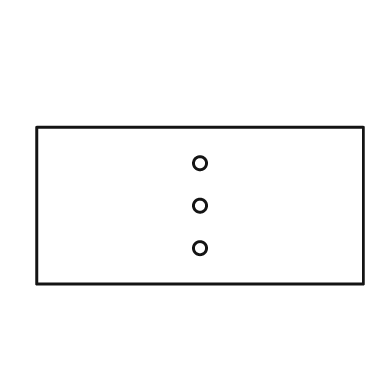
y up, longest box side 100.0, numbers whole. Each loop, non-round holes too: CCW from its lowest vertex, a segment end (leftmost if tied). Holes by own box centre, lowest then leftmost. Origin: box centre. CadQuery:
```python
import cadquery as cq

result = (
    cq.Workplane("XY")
    .moveTo(-50.0, -24.0)
    .lineTo(50.0, -24.0)
    .lineTo(50.0, 24.0)
    .lineTo(-50.0, 24.0)
    .close()
    .moveTo(0.0, -13.0)
    .circle(2.0)
    .moveTo(0.0, 0.0)
    .circle(2.0)
    .moveTo(0.0, 13.0)
    .circle(2.0)
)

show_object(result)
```